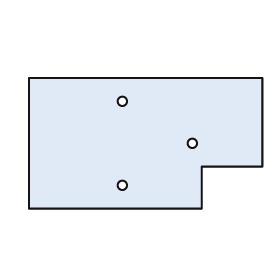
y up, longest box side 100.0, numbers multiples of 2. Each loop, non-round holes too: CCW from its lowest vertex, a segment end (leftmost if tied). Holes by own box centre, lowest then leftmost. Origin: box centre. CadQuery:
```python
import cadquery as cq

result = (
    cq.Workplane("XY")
    .moveTo(-50.0, -28.0)
    .lineTo(24.0, -28.0)
    .lineTo(24.0, -10.0)
    .lineTo(50.0, -10.0)
    .lineTo(50.0, 28.0)
    .lineTo(-50.0, 28.0)
    .close()
    .moveTo(-10.0, -18.0)
    .circle(2.0)
    .moveTo(20.0, 0.0)
    .circle(2.0)
    .moveTo(-10.0, 18.0)
    .circle(2.0)
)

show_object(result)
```